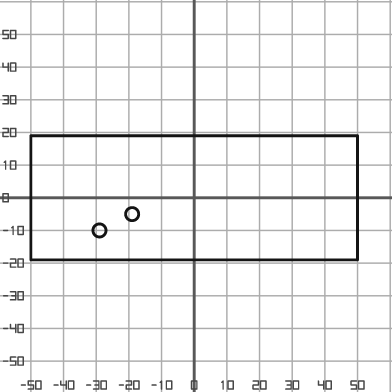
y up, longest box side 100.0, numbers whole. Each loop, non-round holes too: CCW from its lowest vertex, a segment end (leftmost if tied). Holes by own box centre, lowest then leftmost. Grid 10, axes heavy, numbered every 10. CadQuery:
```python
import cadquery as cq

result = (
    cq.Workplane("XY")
    .moveTo(-50.0, -19.0)
    .lineTo(50.0, -19.0)
    .lineTo(50.0, 19.0)
    .lineTo(-50.0, 19.0)
    .close()
    .moveTo(-29.0, -10.0)
    .circle(2.0)
    .moveTo(-19.0, -5.0)
    .circle(2.0)
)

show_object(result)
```